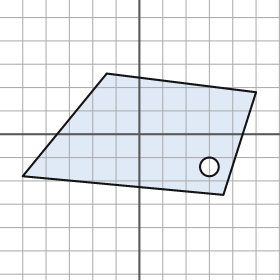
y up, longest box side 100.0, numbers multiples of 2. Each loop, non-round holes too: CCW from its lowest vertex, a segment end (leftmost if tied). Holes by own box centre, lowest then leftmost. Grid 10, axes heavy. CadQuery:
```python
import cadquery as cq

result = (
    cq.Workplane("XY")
    .moveTo(36.0, -26.0)
    .lineTo(50.0, 18.0)
    .lineTo(-14.0, 26.0)
    .lineTo(-50.0, -18.0)
    .close()
    .moveTo(30.0, -14.0)
    .circle(4.0)
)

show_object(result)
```